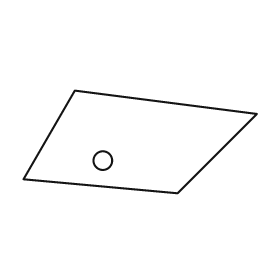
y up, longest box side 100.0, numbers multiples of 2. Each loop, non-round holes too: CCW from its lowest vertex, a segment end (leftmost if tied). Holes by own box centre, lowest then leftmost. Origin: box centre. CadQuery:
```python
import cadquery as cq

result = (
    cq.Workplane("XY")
    .moveTo(16.0, -22.0)
    .lineTo(50.0, 12.0)
    .lineTo(-28.0, 22.0)
    .lineTo(-50.0, -16.0)
    .close()
    .moveTo(-16.0, -8.0)
    .circle(4.0)
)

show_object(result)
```